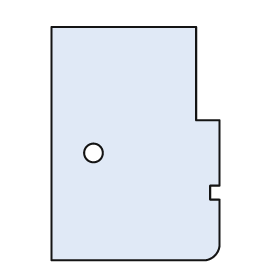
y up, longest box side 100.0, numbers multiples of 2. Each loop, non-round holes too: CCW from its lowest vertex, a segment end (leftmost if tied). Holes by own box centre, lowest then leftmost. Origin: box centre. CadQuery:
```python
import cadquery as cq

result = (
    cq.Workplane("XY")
    .moveTo(-36.0, -50.0)
    .lineTo(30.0, -50.0)
    .threePointArc((34.0, -48.0), (36.0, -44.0))
    .lineTo(36.0, -24.0)
    .lineTo(32.0, -24.0)
    .lineTo(32.0, -18.0)
    .lineTo(36.0, -18.0)
    .lineTo(36.0, 10.0)
    .lineTo(26.0, 10.0)
    .lineTo(26.0, 50.0)
    .lineTo(-36.0, 50.0)
    .close()
    .moveTo(-18.0, -4.0)
    .circle(4.0)
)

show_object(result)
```